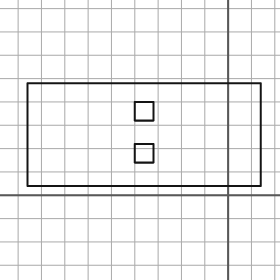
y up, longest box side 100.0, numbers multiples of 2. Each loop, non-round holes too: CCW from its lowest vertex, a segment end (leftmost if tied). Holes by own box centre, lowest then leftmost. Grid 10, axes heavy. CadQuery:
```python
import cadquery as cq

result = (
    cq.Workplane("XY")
    .moveTo(-86.0, 4.0)
    .lineTo(14.0, 4.0)
    .lineTo(14.0, 48.0)
    .lineTo(-86.0, 48.0)
    .close()
    .moveTo(-40.0, 14.0)
    .lineTo(-32.0, 14.0)
    .lineTo(-32.0, 22.0)
    .lineTo(-40.0, 22.0)
    .close()
    .moveTo(-40.0, 32.0)
    .lineTo(-32.0, 32.0)
    .lineTo(-32.0, 40.0)
    .lineTo(-40.0, 40.0)
    .close()
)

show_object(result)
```